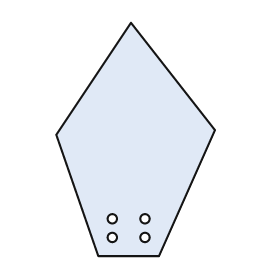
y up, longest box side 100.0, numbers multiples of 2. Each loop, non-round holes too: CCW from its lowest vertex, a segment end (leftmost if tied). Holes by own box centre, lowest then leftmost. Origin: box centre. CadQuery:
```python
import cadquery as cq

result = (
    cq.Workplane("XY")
    .moveTo(-16.0, -50.0)
    .lineTo(10.0, -50.0)
    .lineTo(34.0, 4.0)
    .lineTo(-2.0, 50.0)
    .lineTo(-34.0, 2.0)
    .close()
    .moveTo(-10.0, -42.0)
    .circle(2.0)
    .moveTo(4.0, -42.0)
    .circle(2.0)
    .moveTo(-10.0, -34.0)
    .circle(2.0)
    .moveTo(4.0, -34.0)
    .circle(2.0)
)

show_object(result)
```